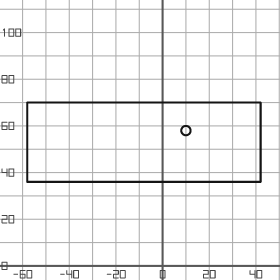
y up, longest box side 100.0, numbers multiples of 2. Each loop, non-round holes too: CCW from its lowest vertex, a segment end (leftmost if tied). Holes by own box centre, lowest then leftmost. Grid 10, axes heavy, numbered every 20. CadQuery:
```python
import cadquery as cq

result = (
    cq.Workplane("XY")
    .moveTo(-58.0, 36.0)
    .lineTo(42.0, 36.0)
    .lineTo(42.0, 70.0)
    .lineTo(-58.0, 70.0)
    .close()
    .moveTo(10.0, 58.0)
    .circle(2.0)
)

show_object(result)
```